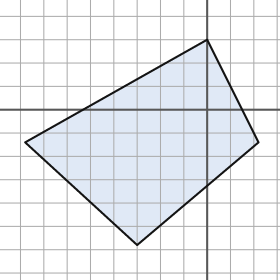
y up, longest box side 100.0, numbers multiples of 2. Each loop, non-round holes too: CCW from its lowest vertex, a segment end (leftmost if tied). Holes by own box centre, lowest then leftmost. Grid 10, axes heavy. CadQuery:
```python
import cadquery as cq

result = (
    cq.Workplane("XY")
    .moveTo(-30.0, -58.0)
    .lineTo(22.0, -14.0)
    .lineTo(0.0, 30.0)
    .lineTo(-78.0, -14.0)
    .close()
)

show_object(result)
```